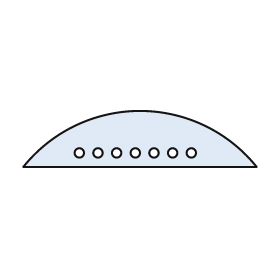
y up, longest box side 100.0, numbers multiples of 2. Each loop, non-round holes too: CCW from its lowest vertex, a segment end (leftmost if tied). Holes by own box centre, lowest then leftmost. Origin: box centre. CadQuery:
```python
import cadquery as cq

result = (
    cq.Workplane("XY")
    .moveTo(-50.0, -12.0)
    .lineTo(50.0, -12.0)
    .threePointArc((0.0, 12.0), (-50.0, -12.0))
    .close()
    .moveTo(-26.0, -6.0)
    .circle(2.0)
    .moveTo(-18.0, -6.0)
    .circle(2.0)
    .moveTo(-10.0, -6.0)
    .circle(2.0)
    .moveTo(-2.0, -6.0)
    .circle(2.0)
    .moveTo(6.0, -6.0)
    .circle(2.0)
    .moveTo(14.0, -6.0)
    .circle(2.0)
    .moveTo(22.0, -6.0)
    .circle(2.0)
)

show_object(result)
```